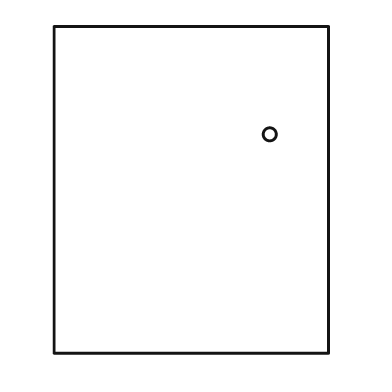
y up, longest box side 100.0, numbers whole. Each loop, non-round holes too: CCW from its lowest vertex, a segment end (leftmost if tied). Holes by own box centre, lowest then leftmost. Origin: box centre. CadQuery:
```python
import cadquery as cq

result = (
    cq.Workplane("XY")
    .moveTo(-42.0, -50.0)
    .lineTo(42.0, -50.0)
    .lineTo(42.0, 50.0)
    .lineTo(-42.0, 50.0)
    .close()
    .moveTo(24.0, 17.0)
    .circle(2.0)
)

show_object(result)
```